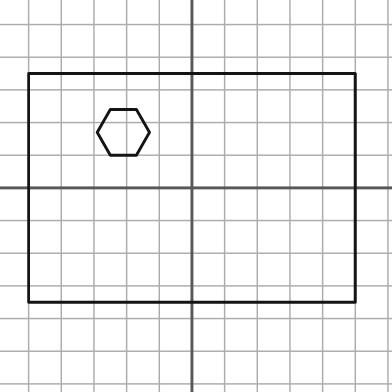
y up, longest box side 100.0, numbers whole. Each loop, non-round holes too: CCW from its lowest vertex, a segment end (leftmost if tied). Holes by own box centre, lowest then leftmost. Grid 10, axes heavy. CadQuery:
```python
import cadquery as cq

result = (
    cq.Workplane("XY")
    .moveTo(-50.0, -35.0)
    .lineTo(50.0, -35.0)
    .lineTo(50.0, 35.0)
    .lineTo(-50.0, 35.0)
    .close()
    .moveTo(-25.0, 10.0)
    .lineTo(-17.0, 10.0)
    .lineTo(-13.0, 17.0)
    .lineTo(-17.0, 24.0)
    .lineTo(-25.0, 24.0)
    .lineTo(-29.0, 17.0)
    .close()
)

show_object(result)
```